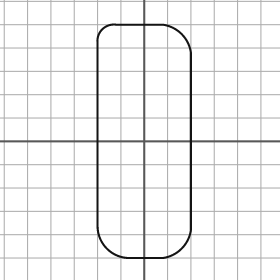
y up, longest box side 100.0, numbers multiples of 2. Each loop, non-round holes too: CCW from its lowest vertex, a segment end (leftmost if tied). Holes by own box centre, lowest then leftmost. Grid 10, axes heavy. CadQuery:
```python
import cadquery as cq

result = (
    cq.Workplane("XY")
    .moveTo(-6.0, -50.0)
    .lineTo(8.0, -50.0)
    .threePointArc((16.0, -46.0), (20.0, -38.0))
    .lineTo(20.0, 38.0)
    .threePointArc((16.0, 46.0), (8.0, 50.0))
    .lineTo(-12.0, 50.0)
    .threePointArc((-18.0, 48.0), (-20.0, 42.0))
    .lineTo(-20.0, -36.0)
    .threePointArc((-16.0, -46.0), (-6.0, -50.0))
    .close()
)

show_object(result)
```